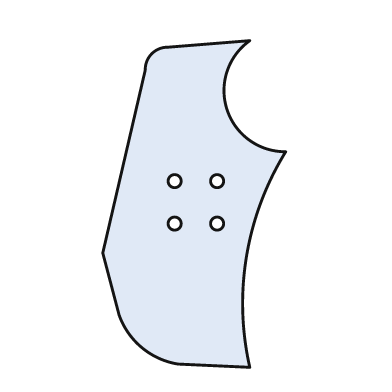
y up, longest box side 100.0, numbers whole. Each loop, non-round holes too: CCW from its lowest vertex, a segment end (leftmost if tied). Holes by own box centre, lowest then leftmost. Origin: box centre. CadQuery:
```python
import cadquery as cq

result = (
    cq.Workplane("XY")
    .moveTo(17.0, -50.0)
    .threePointArc((16.0, -16.0), (28.0, 16.0))
    .threePointArc((10.0, 29.0), (17.0, 50.0))
    .lineTo(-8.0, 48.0)
    .threePointArc((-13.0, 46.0), (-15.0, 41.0))
    .lineTo(-28.0, -15.0)
    .lineTo(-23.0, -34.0)
    .threePointArc((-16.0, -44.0), (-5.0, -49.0))
    .close()
    .moveTo(-6.0, -6.0)
    .circle(2.0)
    .moveTo(7.0, -6.0)
    .circle(2.0)
    .moveTo(-6.0, 7.0)
    .circle(2.0)
    .moveTo(7.0, 7.0)
    .circle(2.0)
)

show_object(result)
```